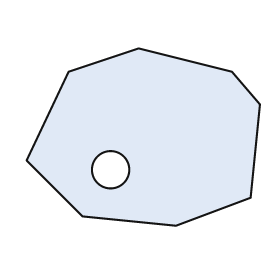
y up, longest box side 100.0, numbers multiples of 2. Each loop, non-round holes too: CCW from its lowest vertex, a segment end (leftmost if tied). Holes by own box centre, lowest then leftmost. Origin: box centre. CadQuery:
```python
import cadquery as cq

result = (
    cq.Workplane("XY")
    .moveTo(14.0, -38.0)
    .lineTo(46.0, -26.0)
    .lineTo(50.0, 14.0)
    .lineTo(38.0, 28.0)
    .lineTo(-2.0, 38.0)
    .lineTo(-32.0, 28.0)
    .lineTo(-50.0, -10.0)
    .lineTo(-26.0, -34.0)
    .close()
    .moveTo(-14.0, -14.0)
    .circle(8.0)
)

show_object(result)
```